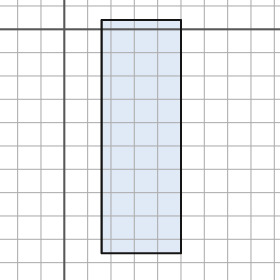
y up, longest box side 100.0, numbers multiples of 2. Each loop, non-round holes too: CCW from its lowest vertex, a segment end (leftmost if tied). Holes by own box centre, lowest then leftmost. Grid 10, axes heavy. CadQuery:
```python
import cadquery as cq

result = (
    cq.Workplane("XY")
    .moveTo(16.0, -96.0)
    .lineTo(50.0, -96.0)
    .lineTo(50.0, 4.0)
    .lineTo(16.0, 4.0)
    .close()
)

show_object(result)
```